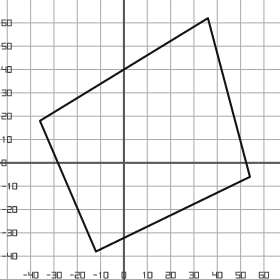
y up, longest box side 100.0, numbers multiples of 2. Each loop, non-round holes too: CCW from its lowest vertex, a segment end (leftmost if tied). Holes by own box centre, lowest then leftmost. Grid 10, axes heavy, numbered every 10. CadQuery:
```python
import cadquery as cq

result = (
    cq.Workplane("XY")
    .moveTo(-12.0, -38.0)
    .lineTo(54.0, -6.0)
    .lineTo(36.0, 62.0)
    .lineTo(-36.0, 18.0)
    .close()
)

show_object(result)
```